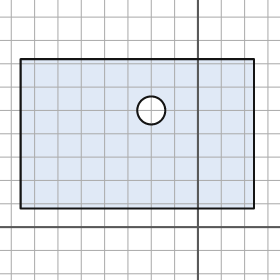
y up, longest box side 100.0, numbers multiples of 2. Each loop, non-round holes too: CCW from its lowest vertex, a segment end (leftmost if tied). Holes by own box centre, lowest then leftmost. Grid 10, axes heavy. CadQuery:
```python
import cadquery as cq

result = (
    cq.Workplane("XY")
    .moveTo(-76.0, 8.0)
    .lineTo(24.0, 8.0)
    .lineTo(24.0, 72.0)
    .lineTo(-76.0, 72.0)
    .close()
    .moveTo(-20.0, 50.0)
    .circle(6.0)
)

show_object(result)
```